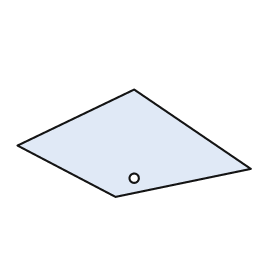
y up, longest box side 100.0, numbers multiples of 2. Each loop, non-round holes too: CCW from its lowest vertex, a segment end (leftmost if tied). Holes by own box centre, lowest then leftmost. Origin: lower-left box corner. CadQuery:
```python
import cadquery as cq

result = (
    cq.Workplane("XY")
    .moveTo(42.0, 0.0)
    .lineTo(100.0, 12.0)
    .lineTo(50.0, 46.0)
    .lineTo(0.0, 22.0)
    .close()
    .moveTo(50.0, 8.0)
    .circle(2.0)
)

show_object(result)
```